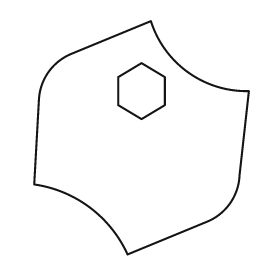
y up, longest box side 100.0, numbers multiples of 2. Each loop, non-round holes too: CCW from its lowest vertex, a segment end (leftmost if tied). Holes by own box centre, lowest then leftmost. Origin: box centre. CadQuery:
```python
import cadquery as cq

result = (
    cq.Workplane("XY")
    .moveTo(-6.0, -50.0)
    .lineTo(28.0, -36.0)
    .threePointArc((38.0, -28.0), (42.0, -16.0))
    .lineTo(46.0, 20.0)
    .threePointArc((20.0, 28.0), (4.0, 50.0))
    .lineTo(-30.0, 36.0)
    .threePointArc((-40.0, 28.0), (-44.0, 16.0))
    .lineTo(-46.0, -20.0)
    .threePointArc((-22.0, -30.0), (-6.0, -50.0))
    .close()
    .moveTo(0.0, 8.0)
    .lineTo(10.0, 14.0)
    .lineTo(10.0, 26.0)
    .lineTo(0.0, 32.0)
    .lineTo(-10.0, 26.0)
    .lineTo(-10.0, 14.0)
    .close()
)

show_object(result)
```